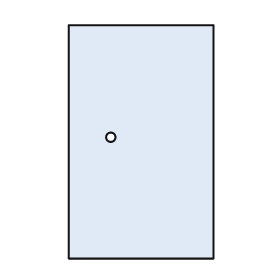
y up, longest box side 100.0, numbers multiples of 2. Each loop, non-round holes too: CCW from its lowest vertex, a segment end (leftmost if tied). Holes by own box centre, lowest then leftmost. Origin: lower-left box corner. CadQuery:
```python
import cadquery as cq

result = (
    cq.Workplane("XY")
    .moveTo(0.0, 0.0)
    .lineTo(62.0, 0.0)
    .lineTo(62.0, 100.0)
    .lineTo(0.0, 100.0)
    .close()
    .moveTo(18.0, 52.0)
    .circle(2.0)
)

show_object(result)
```